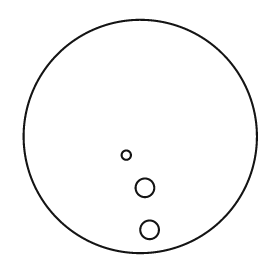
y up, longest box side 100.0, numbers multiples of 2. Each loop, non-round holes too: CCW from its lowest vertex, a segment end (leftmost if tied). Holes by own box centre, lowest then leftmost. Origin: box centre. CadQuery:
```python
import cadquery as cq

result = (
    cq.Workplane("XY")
    .moveTo(0.0, 0.0)
    .circle(50.0)
    .moveTo(4.0, -40.0)
    .circle(4.0)
    .moveTo(2.0, -22.0)
    .circle(4.0)
    .moveTo(-6.0, -8.0)
    .circle(2.0)
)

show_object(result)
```